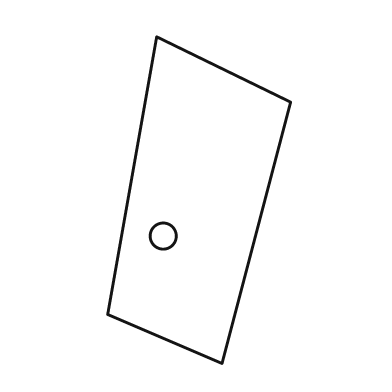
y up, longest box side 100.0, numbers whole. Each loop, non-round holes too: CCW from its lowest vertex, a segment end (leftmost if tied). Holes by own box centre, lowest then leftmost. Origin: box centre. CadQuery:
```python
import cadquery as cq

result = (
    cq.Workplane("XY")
    .moveTo(7.0, -50.0)
    .lineTo(28.0, 30.0)
    .lineTo(-13.0, 50.0)
    .lineTo(-28.0, -35.0)
    .close()
    .moveTo(-11.0, -11.0)
    .circle(4.0)
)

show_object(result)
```